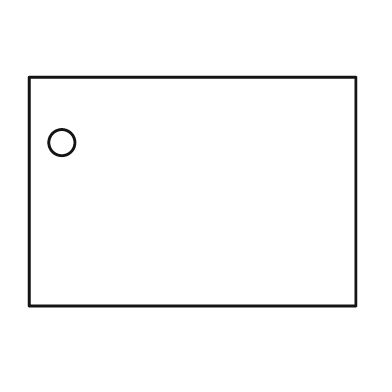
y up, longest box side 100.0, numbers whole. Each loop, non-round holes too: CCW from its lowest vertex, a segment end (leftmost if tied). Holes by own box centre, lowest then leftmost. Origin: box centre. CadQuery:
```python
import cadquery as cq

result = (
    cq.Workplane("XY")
    .moveTo(-50.0, -35.0)
    .lineTo(50.0, -35.0)
    .lineTo(50.0, 35.0)
    .lineTo(-50.0, 35.0)
    .close()
    .moveTo(-40.0, 15.0)
    .circle(4.0)
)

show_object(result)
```